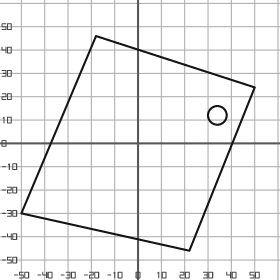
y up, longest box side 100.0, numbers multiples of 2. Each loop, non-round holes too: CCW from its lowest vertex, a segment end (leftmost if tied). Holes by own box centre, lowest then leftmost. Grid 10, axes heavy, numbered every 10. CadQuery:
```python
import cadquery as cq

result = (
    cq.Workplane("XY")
    .moveTo(22.0, -46.0)
    .lineTo(50.0, 24.0)
    .lineTo(-18.0, 46.0)
    .lineTo(-50.0, -30.0)
    .close()
    .moveTo(34.0, 12.0)
    .circle(4.0)
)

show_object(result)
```